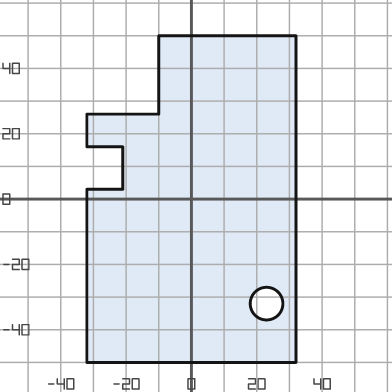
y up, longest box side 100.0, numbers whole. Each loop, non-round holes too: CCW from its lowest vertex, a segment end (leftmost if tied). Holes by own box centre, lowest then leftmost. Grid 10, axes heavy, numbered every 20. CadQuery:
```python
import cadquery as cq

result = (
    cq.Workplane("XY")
    .moveTo(-32.0, -50.0)
    .lineTo(32.0, -50.0)
    .lineTo(32.0, 50.0)
    .lineTo(-10.0, 50.0)
    .lineTo(-10.0, 26.0)
    .lineTo(-32.0, 26.0)
    .lineTo(-32.0, 16.0)
    .lineTo(-21.0, 16.0)
    .lineTo(-21.0, 3.0)
    .lineTo(-32.0, 3.0)
    .close()
    .moveTo(23.0, -32.0)
    .circle(5.0)
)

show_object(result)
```